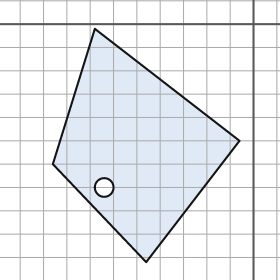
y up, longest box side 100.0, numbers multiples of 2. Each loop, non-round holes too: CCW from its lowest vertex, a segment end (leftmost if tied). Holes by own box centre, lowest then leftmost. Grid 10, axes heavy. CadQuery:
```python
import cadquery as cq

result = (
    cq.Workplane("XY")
    .moveTo(-46.0, -102.0)
    .lineTo(-6.0, -50.0)
    .lineTo(-68.0, -2.0)
    .lineTo(-86.0, -60.0)
    .close()
    .moveTo(-64.0, -70.0)
    .circle(4.0)
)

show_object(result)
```